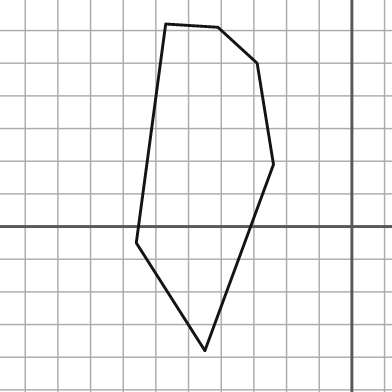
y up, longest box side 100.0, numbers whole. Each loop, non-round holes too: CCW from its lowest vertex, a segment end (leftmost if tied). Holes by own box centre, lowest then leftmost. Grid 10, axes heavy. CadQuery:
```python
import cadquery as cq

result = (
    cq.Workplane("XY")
    .moveTo(-45.0, -38.0)
    .lineTo(-24.0, 19.0)
    .lineTo(-29.0, 50.0)
    .lineTo(-41.0, 61.0)
    .lineTo(-57.0, 62.0)
    .lineTo(-66.0, -5.0)
    .close()
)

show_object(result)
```